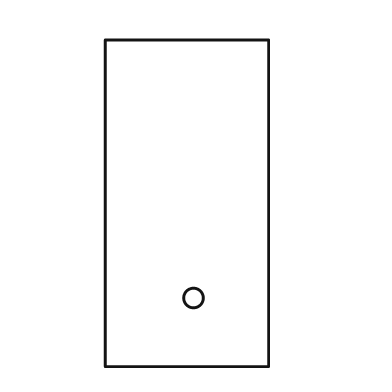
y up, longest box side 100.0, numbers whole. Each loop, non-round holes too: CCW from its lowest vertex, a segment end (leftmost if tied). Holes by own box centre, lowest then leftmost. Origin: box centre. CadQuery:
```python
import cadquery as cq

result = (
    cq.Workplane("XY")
    .moveTo(-25.0, -50.0)
    .lineTo(25.0, -50.0)
    .lineTo(25.0, 50.0)
    .lineTo(-25.0, 50.0)
    .close()
    .moveTo(2.0, -29.0)
    .circle(3.0)
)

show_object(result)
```